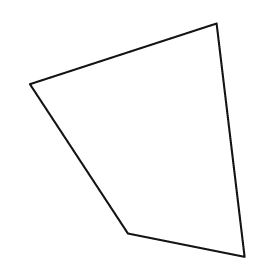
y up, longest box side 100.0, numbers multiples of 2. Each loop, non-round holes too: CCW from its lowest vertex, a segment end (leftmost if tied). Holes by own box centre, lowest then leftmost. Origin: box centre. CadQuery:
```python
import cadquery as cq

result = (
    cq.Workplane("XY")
    .moveTo(46.0, -50.0)
    .lineTo(34.0, 50.0)
    .lineTo(-46.0, 24.0)
    .lineTo(-4.0, -40.0)
    .close()
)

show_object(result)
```